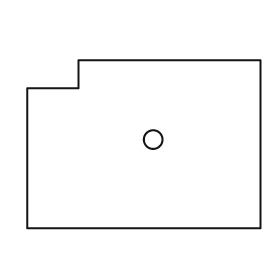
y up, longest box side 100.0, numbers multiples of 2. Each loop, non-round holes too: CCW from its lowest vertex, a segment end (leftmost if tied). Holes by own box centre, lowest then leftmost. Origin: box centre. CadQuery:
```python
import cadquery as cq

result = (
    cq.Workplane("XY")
    .moveTo(-50.0, -36.0)
    .lineTo(50.0, -36.0)
    .lineTo(50.0, 36.0)
    .lineTo(-28.0, 36.0)
    .lineTo(-28.0, 24.0)
    .lineTo(-50.0, 24.0)
    .close()
    .moveTo(4.0, 2.0)
    .circle(4.0)
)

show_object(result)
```